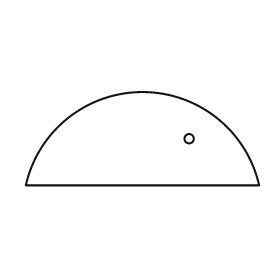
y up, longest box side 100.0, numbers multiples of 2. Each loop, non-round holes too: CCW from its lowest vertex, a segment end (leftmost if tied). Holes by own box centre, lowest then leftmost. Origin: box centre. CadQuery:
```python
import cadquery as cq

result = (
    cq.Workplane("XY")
    .moveTo(-50.0, -20.0)
    .lineTo(50.0, -20.0)
    .threePointArc((0.0, 20.0), (-50.0, -20.0))
    .close()
    .moveTo(20.0, 0.0)
    .circle(2.0)
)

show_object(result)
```